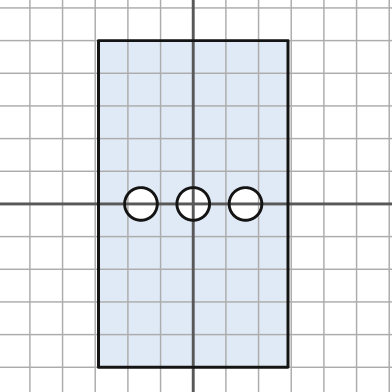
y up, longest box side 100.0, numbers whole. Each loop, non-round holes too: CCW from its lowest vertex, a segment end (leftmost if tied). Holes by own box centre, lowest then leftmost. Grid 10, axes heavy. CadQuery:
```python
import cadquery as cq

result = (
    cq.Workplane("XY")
    .moveTo(-29.0, -50.0)
    .lineTo(29.0, -50.0)
    .lineTo(29.0, 50.0)
    .lineTo(-29.0, 50.0)
    .close()
    .moveTo(-16.0, 0.0)
    .circle(5.0)
    .moveTo(0.0, 0.0)
    .circle(5.0)
    .moveTo(16.0, 0.0)
    .circle(5.0)
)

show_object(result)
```